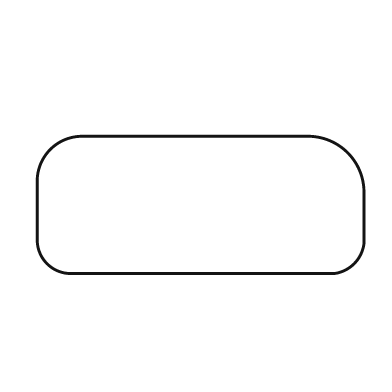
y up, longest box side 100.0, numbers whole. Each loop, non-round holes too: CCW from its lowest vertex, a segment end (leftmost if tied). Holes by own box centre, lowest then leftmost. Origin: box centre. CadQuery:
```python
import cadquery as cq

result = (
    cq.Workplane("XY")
    .moveTo(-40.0, -21.0)
    .lineTo(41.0, -21.0)
    .threePointArc((47.0, -18.0), (50.0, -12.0))
    .lineTo(50.0, 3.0)
    .threePointArc((45.0, 16.0), (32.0, 21.0))
    .lineTo(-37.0, 21.0)
    .threePointArc((-46.0, 17.0), (-50.0, 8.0))
    .lineTo(-50.0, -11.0)
    .threePointArc((-47.0, -18.0), (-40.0, -21.0))
    .close()
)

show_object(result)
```